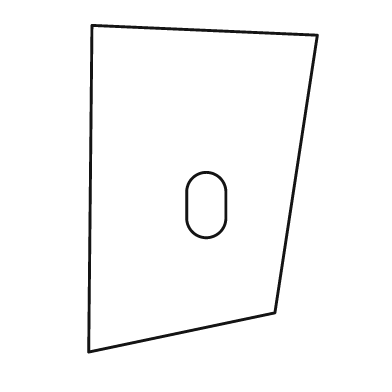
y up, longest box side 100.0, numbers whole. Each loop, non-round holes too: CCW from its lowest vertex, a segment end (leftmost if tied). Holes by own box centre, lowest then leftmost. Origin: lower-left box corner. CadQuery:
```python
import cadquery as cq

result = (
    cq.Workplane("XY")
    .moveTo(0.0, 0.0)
    .lineTo(57.0, 12.0)
    .lineTo(70.0, 97.0)
    .lineTo(1.0, 100.0)
    .close()
    .moveTo(30.0, 41.0)
    .threePointArc((36.0, 35.0), (42.0, 41.0))
    .lineTo(42.0, 49.0)
    .threePointArc((36.0, 55.0), (30.0, 49.0))
    .close()
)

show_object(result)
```